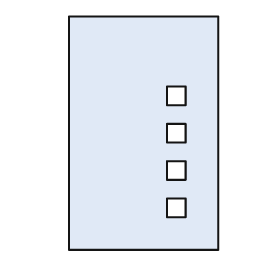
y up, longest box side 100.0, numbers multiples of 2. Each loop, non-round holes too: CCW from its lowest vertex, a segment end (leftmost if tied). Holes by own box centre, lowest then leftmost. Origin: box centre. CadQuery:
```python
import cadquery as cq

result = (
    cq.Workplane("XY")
    .moveTo(-32.0, -50.0)
    .lineTo(32.0, -50.0)
    .lineTo(32.0, 50.0)
    .lineTo(-32.0, 50.0)
    .close()
    .moveTo(10.0, -36.0)
    .lineTo(18.0, -36.0)
    .lineTo(18.0, -28.0)
    .lineTo(10.0, -28.0)
    .close()
    .moveTo(10.0, -20.0)
    .lineTo(18.0, -20.0)
    .lineTo(18.0, -12.0)
    .lineTo(10.0, -12.0)
    .close()
    .moveTo(10.0, -4.0)
    .lineTo(18.0, -4.0)
    .lineTo(18.0, 4.0)
    .lineTo(10.0, 4.0)
    .close()
    .moveTo(10.0, 12.0)
    .lineTo(18.0, 12.0)
    .lineTo(18.0, 20.0)
    .lineTo(10.0, 20.0)
    .close()
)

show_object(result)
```